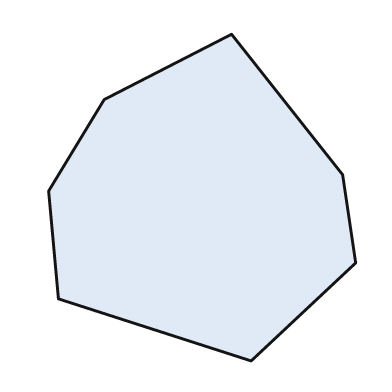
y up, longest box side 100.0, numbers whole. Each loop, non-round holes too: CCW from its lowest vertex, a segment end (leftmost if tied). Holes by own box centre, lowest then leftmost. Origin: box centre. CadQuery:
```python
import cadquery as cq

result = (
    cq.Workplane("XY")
    .moveTo(15.0, -50.0)
    .lineTo(47.0, -20.0)
    .lineTo(43.0, 7.0)
    .lineTo(9.0, 50.0)
    .lineTo(-30.0, 30.0)
    .lineTo(-47.0, 2.0)
    .lineTo(-44.0, -31.0)
    .close()
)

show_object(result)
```